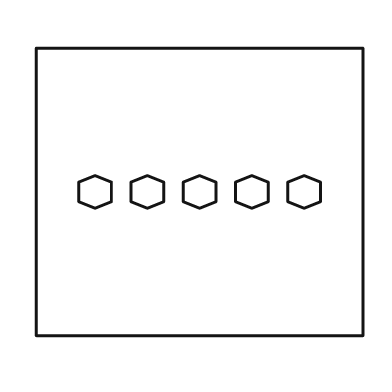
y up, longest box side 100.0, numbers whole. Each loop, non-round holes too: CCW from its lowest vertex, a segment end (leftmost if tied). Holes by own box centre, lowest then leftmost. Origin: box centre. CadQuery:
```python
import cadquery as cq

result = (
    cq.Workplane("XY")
    .moveTo(-50.0, -44.0)
    .lineTo(50.0, -44.0)
    .lineTo(50.0, 44.0)
    .lineTo(-50.0, 44.0)
    .close()
    .moveTo(-32.0, -5.0)
    .lineTo(-27.0, -3.0)
    .lineTo(-27.0, 3.0)
    .lineTo(-32.0, 5.0)
    .lineTo(-37.0, 3.0)
    .lineTo(-37.0, -3.0)
    .close()
    .moveTo(-16.0, -5.0)
    .lineTo(-11.0, -3.0)
    .lineTo(-11.0, 3.0)
    .lineTo(-16.0, 5.0)
    .lineTo(-21.0, 3.0)
    .lineTo(-21.0, -3.0)
    .close()
    .moveTo(0.0, -5.0)
    .lineTo(5.0, -3.0)
    .lineTo(5.0, 3.0)
    .lineTo(0.0, 5.0)
    .lineTo(-5.0, 3.0)
    .lineTo(-5.0, -3.0)
    .close()
    .moveTo(16.0, -5.0)
    .lineTo(21.0, -3.0)
    .lineTo(21.0, 3.0)
    .lineTo(16.0, 5.0)
    .lineTo(11.0, 3.0)
    .lineTo(11.0, -3.0)
    .close()
    .moveTo(32.0, -5.0)
    .lineTo(37.0, -3.0)
    .lineTo(37.0, 3.0)
    .lineTo(32.0, 5.0)
    .lineTo(27.0, 3.0)
    .lineTo(27.0, -3.0)
    .close()
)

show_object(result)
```